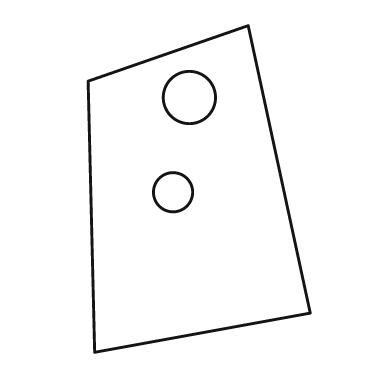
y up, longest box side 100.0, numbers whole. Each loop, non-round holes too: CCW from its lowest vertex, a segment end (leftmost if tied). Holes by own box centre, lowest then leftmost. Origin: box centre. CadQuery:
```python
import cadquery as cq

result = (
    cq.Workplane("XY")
    .moveTo(-32.0, -50.0)
    .lineTo(34.0, -38.0)
    .lineTo(15.0, 50.0)
    .lineTo(-34.0, 33.0)
    .close()
    .moveTo(-8.0, -1.0)
    .circle(6.0)
    .moveTo(-3.0, 28.0)
    .circle(8.0)
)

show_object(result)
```